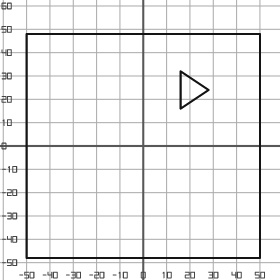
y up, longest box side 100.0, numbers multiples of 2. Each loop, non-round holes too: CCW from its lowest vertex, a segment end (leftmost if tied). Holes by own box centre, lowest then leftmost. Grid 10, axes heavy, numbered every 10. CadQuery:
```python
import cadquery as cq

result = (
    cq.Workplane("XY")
    .moveTo(-50.0, -48.0)
    .lineTo(50.0, -48.0)
    .lineTo(50.0, 48.0)
    .lineTo(-50.0, 48.0)
    .close()
    .moveTo(16.0, 16.0)
    .lineTo(28.0, 24.0)
    .lineTo(16.0, 32.0)
    .close()
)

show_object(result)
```